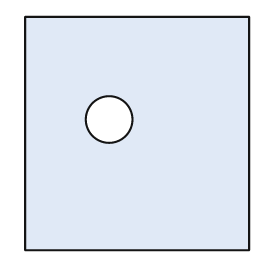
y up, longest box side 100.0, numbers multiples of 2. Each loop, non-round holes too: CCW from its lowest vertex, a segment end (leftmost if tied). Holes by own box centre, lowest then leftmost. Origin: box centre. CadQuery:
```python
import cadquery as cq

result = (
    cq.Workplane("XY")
    .moveTo(-48.0, -50.0)
    .lineTo(48.0, -50.0)
    .lineTo(48.0, 50.0)
    .lineTo(-48.0, 50.0)
    .close()
    .moveTo(-12.0, 6.0)
    .circle(10.0)
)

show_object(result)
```